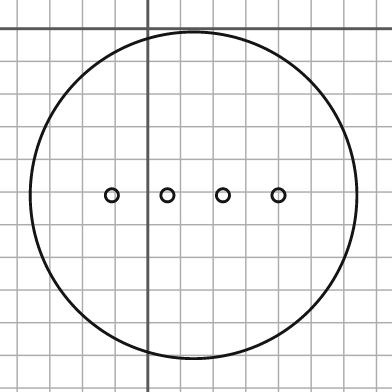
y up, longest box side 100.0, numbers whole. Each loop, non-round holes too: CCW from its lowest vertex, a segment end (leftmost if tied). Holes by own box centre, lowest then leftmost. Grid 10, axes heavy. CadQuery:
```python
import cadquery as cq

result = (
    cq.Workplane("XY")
    .moveTo(14.0, -51.0)
    .circle(50.0)
    .moveTo(-11.0, -51.0)
    .circle(2.0)
    .moveTo(6.0, -51.0)
    .circle(2.0)
    .moveTo(23.0, -51.0)
    .circle(2.0)
    .moveTo(40.0, -51.0)
    .circle(2.0)
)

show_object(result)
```